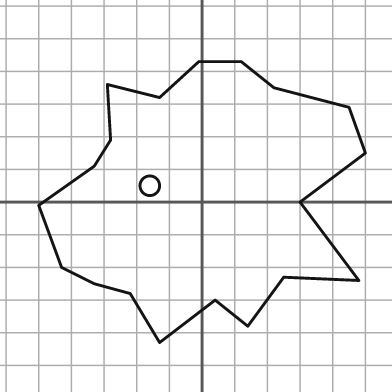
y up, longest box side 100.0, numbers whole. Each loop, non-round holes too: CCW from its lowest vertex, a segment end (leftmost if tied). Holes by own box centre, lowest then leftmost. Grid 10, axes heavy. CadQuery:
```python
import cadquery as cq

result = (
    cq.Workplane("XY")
    .moveTo(-13.0, -43.0)
    .lineTo(4.0, -30.0)
    .lineTo(14.0, -38.0)
    .lineTo(25.0, -23.0)
    .lineTo(48.0, -24.0)
    .lineTo(30.0, 0.0)
    .lineTo(50.0, 15.0)
    .lineTo(45.0, 29.0)
    .lineTo(22.0, 35.0)
    .lineTo(12.0, 43.0)
    .lineTo(-1.0, 43.0)
    .lineTo(-13.0, 32.0)
    .lineTo(-29.0, 36.0)
    .lineTo(-28.0, 19.0)
    .lineTo(-33.0, 11.0)
    .lineTo(-50.0, -1.0)
    .lineTo(-43.0, -20.0)
    .lineTo(-33.0, -25.0)
    .lineTo(-22.0, -28.0)
    .close()
    .moveTo(-16.0, 5.0)
    .circle(3.0)
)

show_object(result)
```